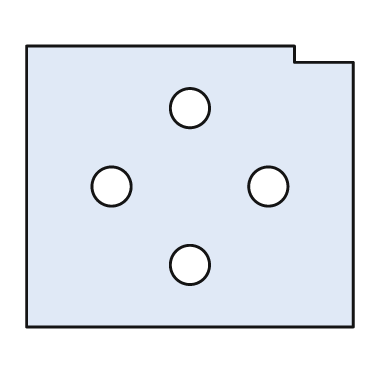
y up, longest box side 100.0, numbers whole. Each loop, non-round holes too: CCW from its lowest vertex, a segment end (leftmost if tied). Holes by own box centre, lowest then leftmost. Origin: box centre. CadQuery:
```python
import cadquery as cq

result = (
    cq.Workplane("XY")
    .moveTo(-50.0, -43.0)
    .lineTo(50.0, -43.0)
    .lineTo(50.0, 38.0)
    .lineTo(32.0, 38.0)
    .lineTo(32.0, 43.0)
    .lineTo(-50.0, 43.0)
    .close()
    .moveTo(0.0, -24.0)
    .circle(6.0)
    .moveTo(-24.0, 0.0)
    .circle(6.0)
    .moveTo(24.0, 0.0)
    .circle(6.0)
    .moveTo(0.0, 24.0)
    .circle(6.0)
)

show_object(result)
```